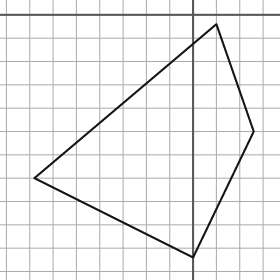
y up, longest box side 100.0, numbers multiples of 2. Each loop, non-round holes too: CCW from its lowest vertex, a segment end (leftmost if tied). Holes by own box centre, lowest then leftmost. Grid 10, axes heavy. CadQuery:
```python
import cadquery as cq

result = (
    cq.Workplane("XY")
    .moveTo(0.0, -104.0)
    .lineTo(26.0, -50.0)
    .lineTo(10.0, -4.0)
    .lineTo(-68.0, -70.0)
    .close()
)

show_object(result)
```